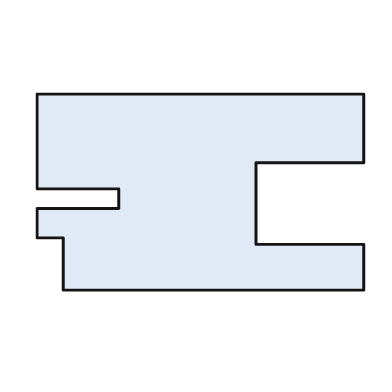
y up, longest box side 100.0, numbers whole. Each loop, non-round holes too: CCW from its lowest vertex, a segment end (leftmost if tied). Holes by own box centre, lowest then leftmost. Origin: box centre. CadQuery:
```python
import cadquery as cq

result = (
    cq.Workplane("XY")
    .moveTo(-42.0, -30.0)
    .lineTo(50.0, -30.0)
    .lineTo(50.0, -16.0)
    .lineTo(17.0, -16.0)
    .lineTo(17.0, 9.0)
    .lineTo(50.0, 9.0)
    .lineTo(50.0, 30.0)
    .lineTo(-50.0, 30.0)
    .lineTo(-50.0, 1.0)
    .lineTo(-25.0, 1.0)
    .lineTo(-25.0, -5.0)
    .lineTo(-50.0, -5.0)
    .lineTo(-50.0, -14.0)
    .lineTo(-42.0, -14.0)
    .close()
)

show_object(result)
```